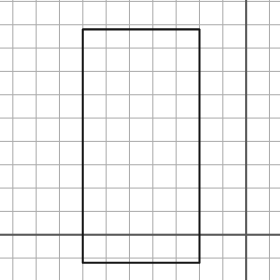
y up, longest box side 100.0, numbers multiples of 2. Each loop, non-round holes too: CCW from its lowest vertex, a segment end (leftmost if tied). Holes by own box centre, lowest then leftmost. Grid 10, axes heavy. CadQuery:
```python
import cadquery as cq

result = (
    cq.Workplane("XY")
    .moveTo(-70.0, -12.0)
    .lineTo(-20.0, -12.0)
    .lineTo(-20.0, 88.0)
    .lineTo(-70.0, 88.0)
    .close()
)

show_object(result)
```